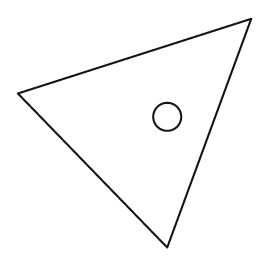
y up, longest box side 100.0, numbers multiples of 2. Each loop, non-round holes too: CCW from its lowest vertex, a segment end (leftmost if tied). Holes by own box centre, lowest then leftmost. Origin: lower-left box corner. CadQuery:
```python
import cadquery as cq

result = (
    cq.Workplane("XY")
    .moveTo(64.0, 0.0)
    .lineTo(100.0, 98.0)
    .lineTo(0.0, 66.0)
    .close()
    .moveTo(64.0, 56.0)
    .circle(6.0)
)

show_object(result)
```